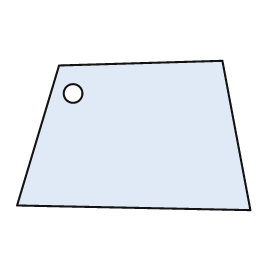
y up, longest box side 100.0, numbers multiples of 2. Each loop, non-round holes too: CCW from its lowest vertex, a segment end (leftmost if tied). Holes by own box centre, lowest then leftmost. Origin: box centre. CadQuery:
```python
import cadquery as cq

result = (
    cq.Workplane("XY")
    .moveTo(50.0, -32.0)
    .lineTo(38.0, 32.0)
    .lineTo(-32.0, 30.0)
    .lineTo(-50.0, -30.0)
    .close()
    .moveTo(-26.0, 18.0)
    .circle(4.0)
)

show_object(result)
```